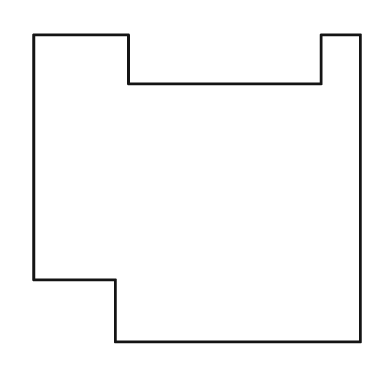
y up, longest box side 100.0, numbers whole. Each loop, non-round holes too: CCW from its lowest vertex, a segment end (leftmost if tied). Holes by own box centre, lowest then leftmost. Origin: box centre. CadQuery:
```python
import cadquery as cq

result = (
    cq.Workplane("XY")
    .moveTo(-25.0, -47.0)
    .lineTo(50.0, -47.0)
    .lineTo(50.0, 47.0)
    .lineTo(38.0, 47.0)
    .lineTo(38.0, 32.0)
    .lineTo(-21.0, 32.0)
    .lineTo(-21.0, 47.0)
    .lineTo(-50.0, 47.0)
    .lineTo(-50.0, -28.0)
    .lineTo(-25.0, -28.0)
    .close()
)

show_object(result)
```